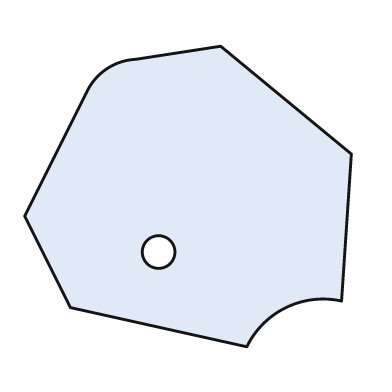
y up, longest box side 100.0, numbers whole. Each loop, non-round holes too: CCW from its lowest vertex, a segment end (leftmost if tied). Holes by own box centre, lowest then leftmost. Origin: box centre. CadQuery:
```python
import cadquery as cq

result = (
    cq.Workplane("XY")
    .moveTo(18.0, -46.0)
    .threePointArc((30.0, -34.0), (47.0, -32.0))
    .lineTo(50.0, 13.0)
    .lineTo(10.0, 46.0)
    .lineTo(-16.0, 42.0)
    .threePointArc((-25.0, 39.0), (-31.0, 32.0))
    .lineTo(-50.0, -6.0)
    .lineTo(-36.0, -34.0)
    .close()
    .moveTo(-9.0, -17.0)
    .circle(5.0)
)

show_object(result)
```